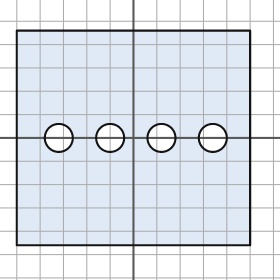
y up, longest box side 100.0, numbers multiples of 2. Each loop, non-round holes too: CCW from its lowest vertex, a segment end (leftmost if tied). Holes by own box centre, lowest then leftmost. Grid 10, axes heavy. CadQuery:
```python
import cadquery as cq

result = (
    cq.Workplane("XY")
    .moveTo(-50.0, -46.0)
    .lineTo(50.0, -46.0)
    .lineTo(50.0, 46.0)
    .lineTo(-50.0, 46.0)
    .close()
    .moveTo(-32.0, 0.0)
    .circle(6.0)
    .moveTo(-10.0, 0.0)
    .circle(6.0)
    .moveTo(12.0, 0.0)
    .circle(6.0)
    .moveTo(34.0, 0.0)
    .circle(6.0)
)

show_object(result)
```